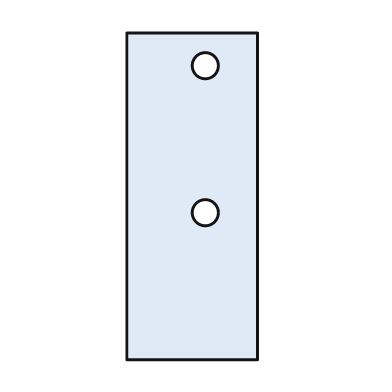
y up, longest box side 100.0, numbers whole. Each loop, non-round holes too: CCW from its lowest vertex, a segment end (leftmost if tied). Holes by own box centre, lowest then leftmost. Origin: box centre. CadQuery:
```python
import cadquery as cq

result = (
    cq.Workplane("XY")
    .moveTo(-20.0, -50.0)
    .lineTo(20.0, -50.0)
    .lineTo(20.0, 50.0)
    .lineTo(-20.0, 50.0)
    .close()
    .moveTo(4.0, -5.0)
    .circle(4.0)
    .moveTo(4.0, 40.0)
    .circle(4.0)
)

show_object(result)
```